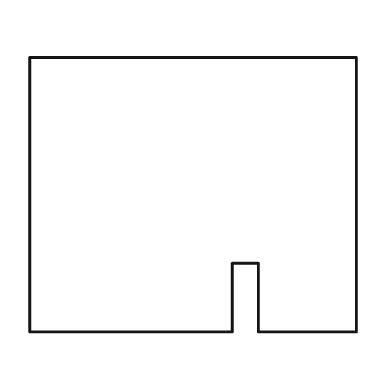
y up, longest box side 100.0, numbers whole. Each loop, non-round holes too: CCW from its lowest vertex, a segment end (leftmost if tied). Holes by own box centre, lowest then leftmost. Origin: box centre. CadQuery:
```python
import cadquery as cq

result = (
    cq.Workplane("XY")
    .moveTo(-50.0, -42.0)
    .lineTo(12.0, -42.0)
    .lineTo(12.0, -21.0)
    .lineTo(20.0, -21.0)
    .lineTo(20.0, -42.0)
    .lineTo(50.0, -42.0)
    .lineTo(50.0, 42.0)
    .lineTo(-50.0, 42.0)
    .close()
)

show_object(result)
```